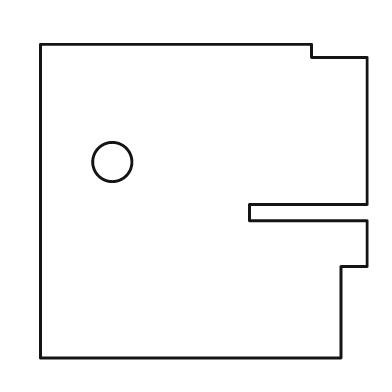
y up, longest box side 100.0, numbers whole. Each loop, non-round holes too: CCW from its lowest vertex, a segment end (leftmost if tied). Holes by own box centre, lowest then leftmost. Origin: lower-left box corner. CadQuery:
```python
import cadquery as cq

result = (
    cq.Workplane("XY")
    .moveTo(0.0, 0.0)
    .lineTo(92.0, 0.0)
    .lineTo(92.0, 28.0)
    .lineTo(100.0, 28.0)
    .lineTo(100.0, 42.0)
    .lineTo(64.0, 42.0)
    .lineTo(64.0, 47.0)
    .lineTo(100.0, 47.0)
    .lineTo(100.0, 92.0)
    .lineTo(83.0, 92.0)
    .lineTo(83.0, 96.0)
    .lineTo(0.0, 96.0)
    .close()
    .moveTo(22.0, 60.0)
    .circle(6.0)
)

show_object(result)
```